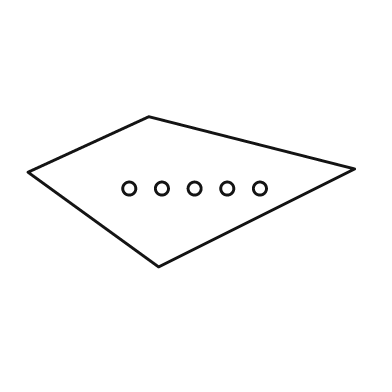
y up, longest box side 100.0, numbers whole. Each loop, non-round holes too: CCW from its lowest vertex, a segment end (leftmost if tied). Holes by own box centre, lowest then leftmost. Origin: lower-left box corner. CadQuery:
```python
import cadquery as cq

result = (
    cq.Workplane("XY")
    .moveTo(40.0, 0.0)
    .lineTo(100.0, 30.0)
    .lineTo(37.0, 46.0)
    .lineTo(0.0, 29.0)
    .close()
    .moveTo(31.0, 24.0)
    .circle(2.0)
    .moveTo(41.0, 24.0)
    .circle(2.0)
    .moveTo(51.0, 24.0)
    .circle(2.0)
    .moveTo(61.0, 24.0)
    .circle(2.0)
    .moveTo(71.0, 24.0)
    .circle(2.0)
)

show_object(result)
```